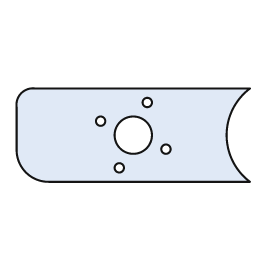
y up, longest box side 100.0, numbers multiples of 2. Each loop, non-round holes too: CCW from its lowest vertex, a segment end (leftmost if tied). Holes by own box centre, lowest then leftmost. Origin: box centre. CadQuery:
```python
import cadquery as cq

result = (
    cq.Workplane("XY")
    .moveTo(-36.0, -20.0)
    .lineTo(50.0, -20.0)
    .threePointArc((40.0, 0.0), (50.0, 20.0))
    .lineTo(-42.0, 20.0)
    .threePointArc((-48.0, 18.0), (-50.0, 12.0))
    .lineTo(-50.0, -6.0)
    .threePointArc((-46.0, -16.0), (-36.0, -20.0))
    .close()
    .moveTo(-6.0, -14.0)
    .circle(2.0)
    .moveTo(14.0, -6.0)
    .circle(2.0)
    .moveTo(0.0, 0.0)
    .circle(8.0)
    .moveTo(-14.0, 6.0)
    .circle(2.0)
    .moveTo(6.0, 14.0)
    .circle(2.0)
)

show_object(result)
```